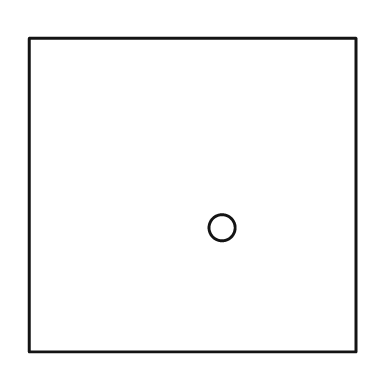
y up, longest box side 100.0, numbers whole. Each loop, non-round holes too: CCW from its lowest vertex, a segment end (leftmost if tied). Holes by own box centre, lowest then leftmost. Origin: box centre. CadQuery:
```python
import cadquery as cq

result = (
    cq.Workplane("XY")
    .moveTo(-50.0, -48.0)
    .lineTo(50.0, -48.0)
    .lineTo(50.0, 48.0)
    .lineTo(-50.0, 48.0)
    .close()
    .moveTo(9.0, -10.0)
    .circle(4.0)
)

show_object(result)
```